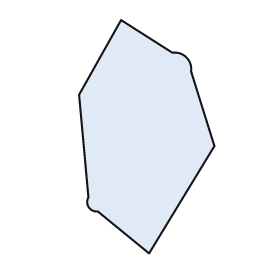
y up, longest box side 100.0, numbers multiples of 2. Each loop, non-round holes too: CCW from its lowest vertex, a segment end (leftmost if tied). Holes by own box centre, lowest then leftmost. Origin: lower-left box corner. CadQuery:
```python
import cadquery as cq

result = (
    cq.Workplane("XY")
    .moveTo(30.0, 0.0)
    .lineTo(58.0, 46.0)
    .lineTo(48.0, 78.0)
    .threePointArc((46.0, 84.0), (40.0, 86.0))
    .lineTo(18.0, 100.0)
    .lineTo(0.0, 68.0)
    .lineTo(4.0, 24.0)
    .threePointArc((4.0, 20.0), (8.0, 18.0))
    .close()
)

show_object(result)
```